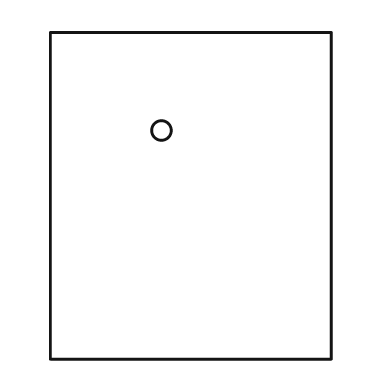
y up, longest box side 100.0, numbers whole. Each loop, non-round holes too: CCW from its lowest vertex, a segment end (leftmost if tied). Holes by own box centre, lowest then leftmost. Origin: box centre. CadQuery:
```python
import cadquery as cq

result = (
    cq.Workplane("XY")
    .moveTo(-43.0, -50.0)
    .lineTo(43.0, -50.0)
    .lineTo(43.0, 50.0)
    .lineTo(-43.0, 50.0)
    .close()
    .moveTo(-9.0, 20.0)
    .circle(3.0)
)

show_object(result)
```